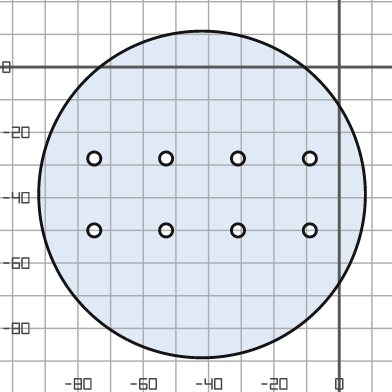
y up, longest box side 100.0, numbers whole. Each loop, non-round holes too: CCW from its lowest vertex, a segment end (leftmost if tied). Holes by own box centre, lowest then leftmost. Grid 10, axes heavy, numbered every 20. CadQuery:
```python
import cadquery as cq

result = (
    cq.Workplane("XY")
    .moveTo(-42.0, -39.0)
    .circle(50.0)
    .moveTo(-75.0, -50.0)
    .circle(2.0)
    .moveTo(-53.0, -50.0)
    .circle(2.0)
    .moveTo(-31.0, -50.0)
    .circle(2.0)
    .moveTo(-9.0, -50.0)
    .circle(2.0)
    .moveTo(-75.0, -28.0)
    .circle(2.0)
    .moveTo(-53.0, -28.0)
    .circle(2.0)
    .moveTo(-31.0, -28.0)
    .circle(2.0)
    .moveTo(-9.0, -28.0)
    .circle(2.0)
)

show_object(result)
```